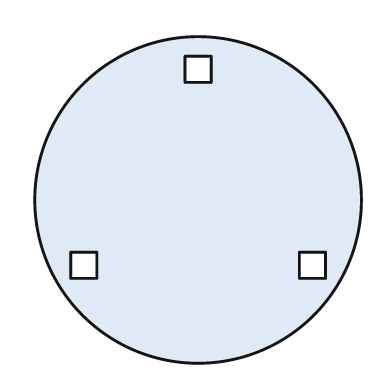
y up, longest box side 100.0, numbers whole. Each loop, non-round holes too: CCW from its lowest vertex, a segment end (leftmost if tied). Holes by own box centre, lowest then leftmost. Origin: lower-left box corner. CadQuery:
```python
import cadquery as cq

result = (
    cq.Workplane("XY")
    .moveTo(50.0, 50.0)
    .circle(50.0)
    .moveTo(11.0, 26.0)
    .lineTo(19.0, 26.0)
    .lineTo(19.0, 34.0)
    .lineTo(11.0, 34.0)
    .close()
    .moveTo(81.0, 26.0)
    .lineTo(89.0, 26.0)
    .lineTo(89.0, 34.0)
    .lineTo(81.0, 34.0)
    .close()
    .moveTo(46.0, 86.0)
    .lineTo(54.0, 86.0)
    .lineTo(54.0, 94.0)
    .lineTo(46.0, 94.0)
    .close()
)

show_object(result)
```